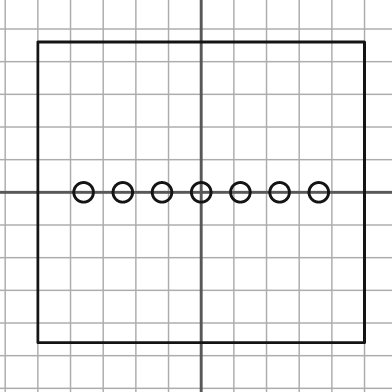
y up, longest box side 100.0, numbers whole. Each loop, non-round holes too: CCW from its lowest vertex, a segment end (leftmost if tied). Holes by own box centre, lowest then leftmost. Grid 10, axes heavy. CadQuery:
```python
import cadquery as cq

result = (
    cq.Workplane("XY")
    .moveTo(-50.0, -46.0)
    .lineTo(50.0, -46.0)
    .lineTo(50.0, 46.0)
    .lineTo(-50.0, 46.0)
    .close()
    .moveTo(-36.0, 0.0)
    .circle(3.0)
    .moveTo(-24.0, 0.0)
    .circle(3.0)
    .moveTo(-12.0, 0.0)
    .circle(3.0)
    .moveTo(0.0, 0.0)
    .circle(3.0)
    .moveTo(12.0, 0.0)
    .circle(3.0)
    .moveTo(24.0, 0.0)
    .circle(3.0)
    .moveTo(36.0, 0.0)
    .circle(3.0)
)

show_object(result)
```